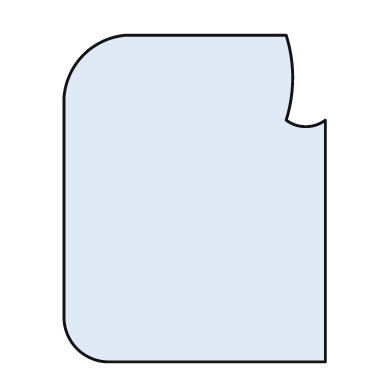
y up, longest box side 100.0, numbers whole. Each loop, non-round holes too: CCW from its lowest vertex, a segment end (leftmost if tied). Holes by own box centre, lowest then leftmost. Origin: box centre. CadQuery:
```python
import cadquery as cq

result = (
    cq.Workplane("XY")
    .moveTo(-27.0, -50.0)
    .lineTo(40.0, -50.0)
    .lineTo(40.0, 24.0)
    .threePointArc((34.0, 22.0), (28.0, 24.0))
    .threePointArc((30.0, 37.0), (28.0, 50.0))
    .lineTo(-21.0, 50.0)
    .threePointArc((-34.0, 44.0), (-40.0, 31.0))
    .lineTo(-40.0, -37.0)
    .threePointArc((-36.0, -46.0), (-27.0, -50.0))
    .close()
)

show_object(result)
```